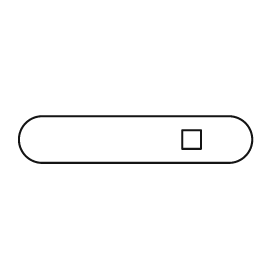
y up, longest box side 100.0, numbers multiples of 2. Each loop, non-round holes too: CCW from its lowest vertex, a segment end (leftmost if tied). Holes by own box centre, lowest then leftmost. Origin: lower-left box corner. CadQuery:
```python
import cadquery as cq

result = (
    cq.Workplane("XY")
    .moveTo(10.0, 0.0)
    .lineTo(90.0, 0.0)
    .threePointArc((100.0, 10.0), (90.0, 20.0))
    .lineTo(10.0, 20.0)
    .threePointArc((0.0, 10.0), (10.0, 0.0))
    .close()
    .moveTo(70.0, 6.0)
    .lineTo(78.0, 6.0)
    .lineTo(78.0, 14.0)
    .lineTo(70.0, 14.0)
    .close()
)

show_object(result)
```